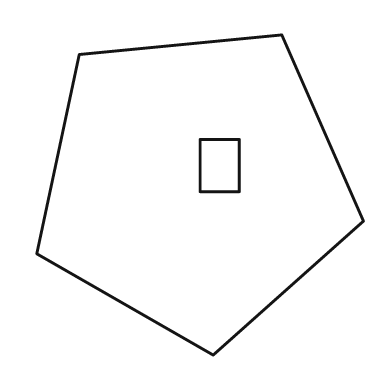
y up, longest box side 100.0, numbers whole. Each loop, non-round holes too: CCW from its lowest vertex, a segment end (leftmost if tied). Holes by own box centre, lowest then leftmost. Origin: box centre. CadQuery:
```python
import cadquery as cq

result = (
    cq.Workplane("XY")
    .moveTo(4.0, -49.0)
    .lineTo(50.0, -8.0)
    .lineTo(25.0, 49.0)
    .lineTo(-37.0, 43.0)
    .lineTo(-50.0, -18.0)
    .close()
    .moveTo(0.0, 1.0)
    .lineTo(12.0, 1.0)
    .lineTo(12.0, 17.0)
    .lineTo(0.0, 17.0)
    .close()
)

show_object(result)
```